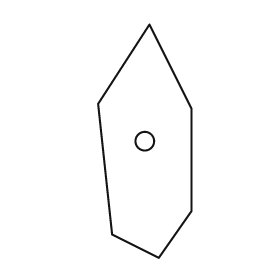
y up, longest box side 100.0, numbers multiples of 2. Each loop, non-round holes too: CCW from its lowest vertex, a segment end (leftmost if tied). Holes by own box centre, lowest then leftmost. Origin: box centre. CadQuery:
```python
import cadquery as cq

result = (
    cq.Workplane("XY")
    .moveTo(6.0, -50.0)
    .lineTo(20.0, -30.0)
    .lineTo(20.0, 14.0)
    .lineTo(2.0, 50.0)
    .lineTo(-20.0, 16.0)
    .lineTo(-14.0, -40.0)
    .close()
    .moveTo(0.0, 0.0)
    .circle(4.0)
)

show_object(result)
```